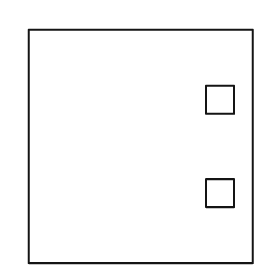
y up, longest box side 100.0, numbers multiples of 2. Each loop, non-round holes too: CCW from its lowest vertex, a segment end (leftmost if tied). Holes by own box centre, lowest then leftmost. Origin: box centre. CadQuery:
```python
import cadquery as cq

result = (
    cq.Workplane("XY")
    .moveTo(-48.0, -50.0)
    .lineTo(48.0, -50.0)
    .lineTo(48.0, 50.0)
    .lineTo(-48.0, 50.0)
    .close()
    .moveTo(28.0, -26.0)
    .lineTo(40.0, -26.0)
    .lineTo(40.0, -14.0)
    .lineTo(28.0, -14.0)
    .close()
    .moveTo(28.0, 14.0)
    .lineTo(40.0, 14.0)
    .lineTo(40.0, 26.0)
    .lineTo(28.0, 26.0)
    .close()
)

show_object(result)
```